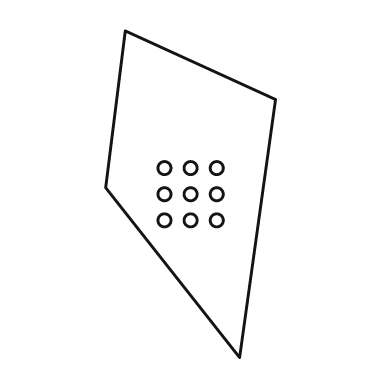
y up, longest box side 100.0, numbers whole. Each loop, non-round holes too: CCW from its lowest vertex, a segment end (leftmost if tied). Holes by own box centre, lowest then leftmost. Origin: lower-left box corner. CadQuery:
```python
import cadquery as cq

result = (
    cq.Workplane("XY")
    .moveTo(41.0, 0.0)
    .lineTo(52.0, 79.0)
    .lineTo(6.0, 100.0)
    .lineTo(0.0, 52.0)
    .close()
    .moveTo(18.0, 42.0)
    .circle(2.0)
    .moveTo(26.0, 42.0)
    .circle(2.0)
    .moveTo(34.0, 42.0)
    .circle(2.0)
    .moveTo(18.0, 50.0)
    .circle(2.0)
    .moveTo(26.0, 50.0)
    .circle(2.0)
    .moveTo(34.0, 50.0)
    .circle(2.0)
    .moveTo(18.0, 58.0)
    .circle(2.0)
    .moveTo(26.0, 58.0)
    .circle(2.0)
    .moveTo(34.0, 58.0)
    .circle(2.0)
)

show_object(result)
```